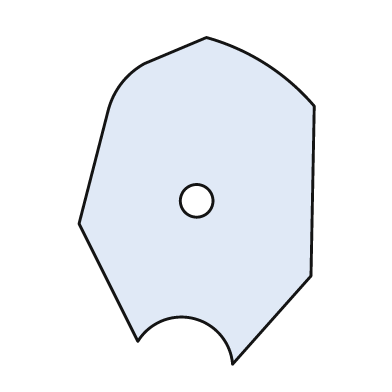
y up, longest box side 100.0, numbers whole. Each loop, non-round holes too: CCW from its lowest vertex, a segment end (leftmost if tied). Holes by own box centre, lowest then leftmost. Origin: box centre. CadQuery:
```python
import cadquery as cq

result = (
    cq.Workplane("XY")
    .moveTo(11.0, -50.0)
    .lineTo(35.0, -23.0)
    .lineTo(36.0, 29.0)
    .threePointArc((21.0, 42.0), (3.0, 50.0))
    .lineTo(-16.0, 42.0)
    .threePointArc((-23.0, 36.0), (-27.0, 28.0))
    .lineTo(-36.0, -7.0)
    .lineTo(-18.0, -43.0)
    .threePointArc((-1.0, -36.0), (11.0, -50.0))
    .close()
    .moveTo(0.0, 0.0)
    .circle(5.0)
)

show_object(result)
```